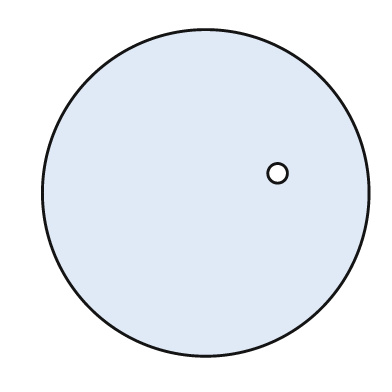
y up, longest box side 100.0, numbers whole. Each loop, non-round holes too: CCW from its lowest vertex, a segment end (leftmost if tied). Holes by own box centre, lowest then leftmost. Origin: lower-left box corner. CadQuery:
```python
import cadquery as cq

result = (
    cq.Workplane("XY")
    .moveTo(50.0, 50.0)
    .circle(50.0)
    .moveTo(72.0, 56.0)
    .circle(3.0)
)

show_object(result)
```